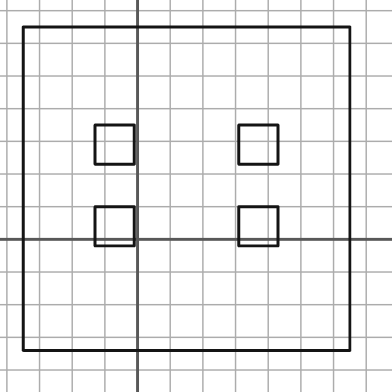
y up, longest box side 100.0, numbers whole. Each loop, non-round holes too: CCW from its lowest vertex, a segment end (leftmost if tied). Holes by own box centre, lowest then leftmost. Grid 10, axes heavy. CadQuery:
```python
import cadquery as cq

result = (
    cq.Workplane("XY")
    .moveTo(-35.0, -34.0)
    .lineTo(65.0, -34.0)
    .lineTo(65.0, 65.0)
    .lineTo(-35.0, 65.0)
    .close()
    .moveTo(-13.0, -2.0)
    .lineTo(-1.0, -2.0)
    .lineTo(-1.0, 10.0)
    .lineTo(-13.0, 10.0)
    .close()
    .moveTo(31.0, -2.0)
    .lineTo(43.0, -2.0)
    .lineTo(43.0, 10.0)
    .lineTo(31.0, 10.0)
    .close()
    .moveTo(-13.0, 23.0)
    .lineTo(-1.0, 23.0)
    .lineTo(-1.0, 35.0)
    .lineTo(-13.0, 35.0)
    .close()
    .moveTo(31.0, 23.0)
    .lineTo(43.0, 23.0)
    .lineTo(43.0, 35.0)
    .lineTo(31.0, 35.0)
    .close()
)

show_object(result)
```